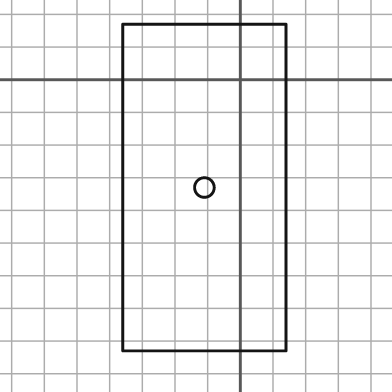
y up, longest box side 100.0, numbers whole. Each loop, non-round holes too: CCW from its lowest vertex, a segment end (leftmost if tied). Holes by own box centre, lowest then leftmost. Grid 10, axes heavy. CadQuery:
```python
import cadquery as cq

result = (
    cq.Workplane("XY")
    .moveTo(-36.0, -83.0)
    .lineTo(14.0, -83.0)
    .lineTo(14.0, 17.0)
    .lineTo(-36.0, 17.0)
    .close()
    .moveTo(-11.0, -33.0)
    .circle(3.0)
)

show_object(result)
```